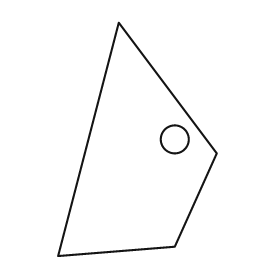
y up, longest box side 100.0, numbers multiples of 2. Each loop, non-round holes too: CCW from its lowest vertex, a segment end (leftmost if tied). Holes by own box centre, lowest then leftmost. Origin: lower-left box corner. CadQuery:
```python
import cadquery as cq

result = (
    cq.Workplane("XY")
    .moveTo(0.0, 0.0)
    .lineTo(50.0, 4.0)
    .lineTo(68.0, 44.0)
    .lineTo(26.0, 100.0)
    .close()
    .moveTo(50.0, 50.0)
    .circle(6.0)
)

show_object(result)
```